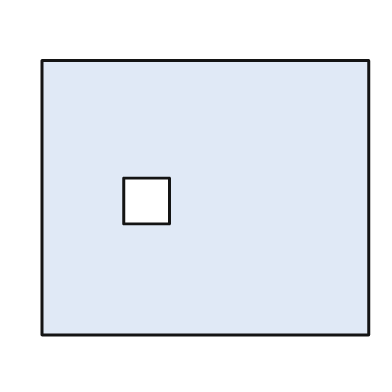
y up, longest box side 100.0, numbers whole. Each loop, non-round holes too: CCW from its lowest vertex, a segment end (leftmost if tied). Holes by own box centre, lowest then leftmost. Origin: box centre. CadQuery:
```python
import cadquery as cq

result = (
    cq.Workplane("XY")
    .moveTo(-50.0, -42.0)
    .lineTo(50.0, -42.0)
    .lineTo(50.0, 42.0)
    .lineTo(-50.0, 42.0)
    .close()
    .moveTo(-25.0, -8.0)
    .lineTo(-11.0, -8.0)
    .lineTo(-11.0, 6.0)
    .lineTo(-25.0, 6.0)
    .close()
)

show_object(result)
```